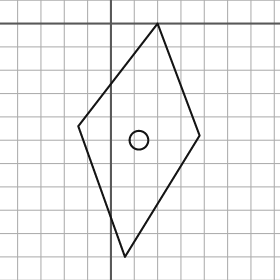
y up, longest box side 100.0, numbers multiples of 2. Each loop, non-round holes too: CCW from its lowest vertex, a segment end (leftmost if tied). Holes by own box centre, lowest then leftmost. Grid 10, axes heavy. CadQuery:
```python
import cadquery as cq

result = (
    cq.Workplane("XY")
    .moveTo(6.0, -100.0)
    .lineTo(38.0, -48.0)
    .lineTo(20.0, 0.0)
    .lineTo(-14.0, -44.0)
    .close()
    .moveTo(12.0, -50.0)
    .circle(4.0)
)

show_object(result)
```